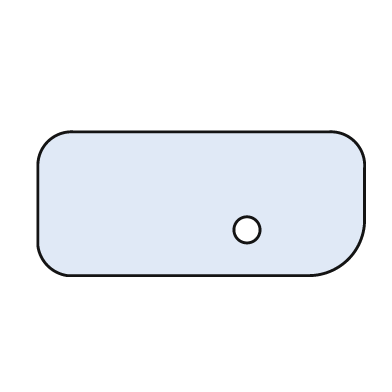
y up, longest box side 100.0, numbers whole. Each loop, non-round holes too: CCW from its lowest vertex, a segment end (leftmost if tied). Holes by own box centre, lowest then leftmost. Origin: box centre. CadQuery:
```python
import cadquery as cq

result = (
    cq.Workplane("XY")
    .moveTo(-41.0, -22.0)
    .lineTo(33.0, -22.0)
    .threePointArc((45.0, -17.0), (50.0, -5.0))
    .lineTo(50.0, 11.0)
    .threePointArc((47.0, 19.0), (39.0, 22.0))
    .lineTo(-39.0, 22.0)
    .threePointArc((-47.0, 19.0), (-50.0, 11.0))
    .lineTo(-50.0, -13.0)
    .threePointArc((-47.0, -19.0), (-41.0, -22.0))
    .close()
    .moveTo(14.0, -8.0)
    .circle(4.0)
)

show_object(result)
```